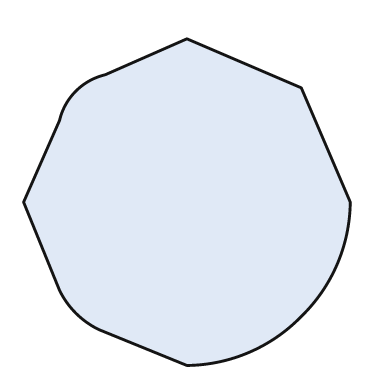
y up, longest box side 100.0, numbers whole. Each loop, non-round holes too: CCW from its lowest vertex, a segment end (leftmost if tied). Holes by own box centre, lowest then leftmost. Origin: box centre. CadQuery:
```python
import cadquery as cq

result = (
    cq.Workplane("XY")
    .moveTo(0.0, -50.0)
    .threePointArc((19.0, -46.0), (35.0, -35.0))
    .threePointArc((46.0, -19.0), (50.0, 0.0))
    .lineTo(35.0, 35.0)
    .lineTo(0.0, 50.0)
    .lineTo(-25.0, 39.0)
    .threePointArc((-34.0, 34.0), (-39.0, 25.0))
    .lineTo(-50.0, 0.0)
    .lineTo(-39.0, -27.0)
    .threePointArc((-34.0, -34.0), (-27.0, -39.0))
    .close()
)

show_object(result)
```